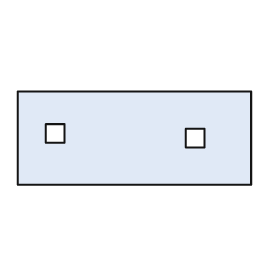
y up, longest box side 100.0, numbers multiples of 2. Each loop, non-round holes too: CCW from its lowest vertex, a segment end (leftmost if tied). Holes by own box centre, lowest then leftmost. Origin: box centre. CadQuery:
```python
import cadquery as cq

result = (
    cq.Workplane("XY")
    .moveTo(-50.0, -20.0)
    .lineTo(50.0, -20.0)
    .lineTo(50.0, 20.0)
    .lineTo(-50.0, 20.0)
    .close()
    .moveTo(22.0, -4.0)
    .lineTo(30.0, -4.0)
    .lineTo(30.0, 4.0)
    .lineTo(22.0, 4.0)
    .close()
    .moveTo(-38.0, -2.0)
    .lineTo(-30.0, -2.0)
    .lineTo(-30.0, 6.0)
    .lineTo(-38.0, 6.0)
    .close()
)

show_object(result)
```